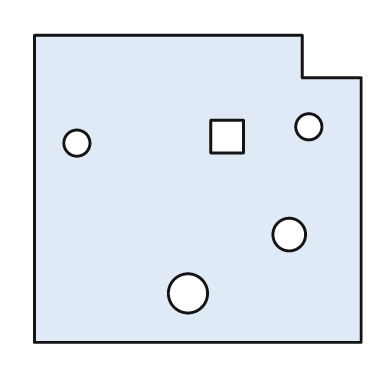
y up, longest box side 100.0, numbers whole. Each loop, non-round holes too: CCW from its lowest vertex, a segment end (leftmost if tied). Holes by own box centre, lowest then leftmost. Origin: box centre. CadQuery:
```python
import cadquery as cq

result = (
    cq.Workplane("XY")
    .moveTo(-50.0, -47.0)
    .lineTo(50.0, -47.0)
    .lineTo(50.0, 34.0)
    .lineTo(32.0, 34.0)
    .lineTo(32.0, 47.0)
    .lineTo(-50.0, 47.0)
    .close()
    .moveTo(-3.0, -32.0)
    .circle(6.0)
    .moveTo(28.0, -14.0)
    .circle(5.0)
    .moveTo(-37.0, 14.0)
    .circle(4.0)
    .moveTo(4.0, 11.0)
    .lineTo(14.0, 11.0)
    .lineTo(14.0, 21.0)
    .lineTo(4.0, 21.0)
    .close()
    .moveTo(34.0, 19.0)
    .circle(4.0)
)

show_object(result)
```